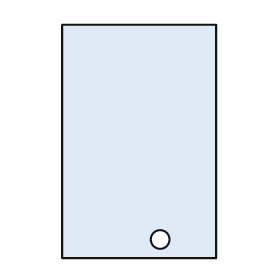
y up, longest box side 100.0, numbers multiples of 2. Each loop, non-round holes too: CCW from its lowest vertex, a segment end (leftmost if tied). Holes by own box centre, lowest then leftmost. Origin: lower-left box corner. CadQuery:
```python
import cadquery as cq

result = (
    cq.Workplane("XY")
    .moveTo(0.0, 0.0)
    .lineTo(66.0, 0.0)
    .lineTo(66.0, 100.0)
    .lineTo(0.0, 100.0)
    .close()
    .moveTo(42.0, 8.0)
    .circle(4.0)
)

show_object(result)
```